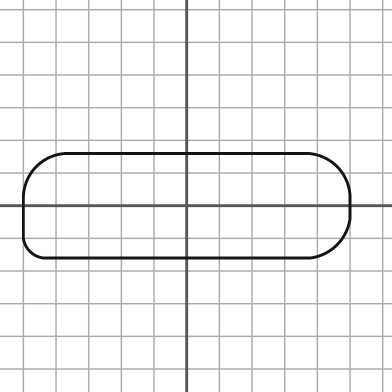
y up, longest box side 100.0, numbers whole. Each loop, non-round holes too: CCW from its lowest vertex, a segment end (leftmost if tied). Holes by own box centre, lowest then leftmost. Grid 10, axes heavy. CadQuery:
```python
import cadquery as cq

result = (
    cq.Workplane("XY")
    .moveTo(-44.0, -16.0)
    .lineTo(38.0, -16.0)
    .threePointArc((46.0, -12.0), (50.0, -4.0))
    .lineTo(50.0, 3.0)
    .threePointArc((46.0, 12.0), (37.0, 16.0))
    .lineTo(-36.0, 16.0)
    .threePointArc((-46.0, 12.0), (-50.0, 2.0))
    .lineTo(-50.0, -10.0)
    .threePointArc((-48.0, -14.0), (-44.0, -16.0))
    .close()
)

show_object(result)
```